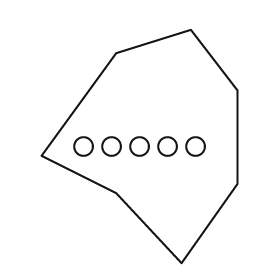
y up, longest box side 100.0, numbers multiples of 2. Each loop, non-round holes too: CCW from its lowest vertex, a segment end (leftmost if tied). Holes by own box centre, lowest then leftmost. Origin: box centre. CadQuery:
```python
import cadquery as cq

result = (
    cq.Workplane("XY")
    .moveTo(18.0, -50.0)
    .lineTo(42.0, -16.0)
    .lineTo(42.0, 24.0)
    .lineTo(22.0, 50.0)
    .lineTo(-10.0, 40.0)
    .lineTo(-42.0, -4.0)
    .lineTo(-10.0, -20.0)
    .close()
    .moveTo(-24.0, 0.0)
    .circle(4.0)
    .moveTo(-12.0, 0.0)
    .circle(4.0)
    .moveTo(0.0, 0.0)
    .circle(4.0)
    .moveTo(12.0, 0.0)
    .circle(4.0)
    .moveTo(24.0, 0.0)
    .circle(4.0)
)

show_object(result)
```